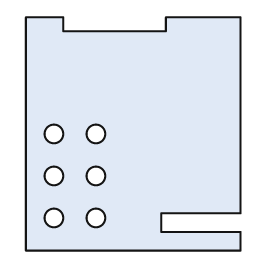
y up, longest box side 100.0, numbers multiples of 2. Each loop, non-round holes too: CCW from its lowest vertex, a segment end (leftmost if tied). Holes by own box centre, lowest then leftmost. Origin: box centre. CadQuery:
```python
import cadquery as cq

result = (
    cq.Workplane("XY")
    .moveTo(-46.0, -50.0)
    .lineTo(46.0, -50.0)
    .lineTo(46.0, -42.0)
    .lineTo(12.0, -42.0)
    .lineTo(12.0, -34.0)
    .lineTo(46.0, -34.0)
    .lineTo(46.0, 50.0)
    .lineTo(14.0, 50.0)
    .lineTo(14.0, 44.0)
    .lineTo(-30.0, 44.0)
    .lineTo(-30.0, 50.0)
    .lineTo(-46.0, 50.0)
    .close()
    .moveTo(-34.0, -36.0)
    .circle(4.0)
    .moveTo(-16.0, -36.0)
    .circle(4.0)
    .moveTo(-34.0, -18.0)
    .circle(4.0)
    .moveTo(-16.0, -18.0)
    .circle(4.0)
    .moveTo(-34.0, 0.0)
    .circle(4.0)
    .moveTo(-16.0, 0.0)
    .circle(4.0)
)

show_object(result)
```